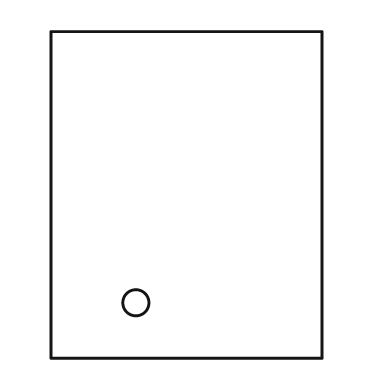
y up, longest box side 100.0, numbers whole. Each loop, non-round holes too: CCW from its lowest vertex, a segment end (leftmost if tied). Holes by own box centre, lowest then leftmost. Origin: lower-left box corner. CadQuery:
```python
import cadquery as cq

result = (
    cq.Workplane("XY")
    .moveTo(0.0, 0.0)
    .lineTo(83.0, 0.0)
    .lineTo(83.0, 100.0)
    .lineTo(0.0, 100.0)
    .close()
    .moveTo(26.0, 17.0)
    .circle(4.0)
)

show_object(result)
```